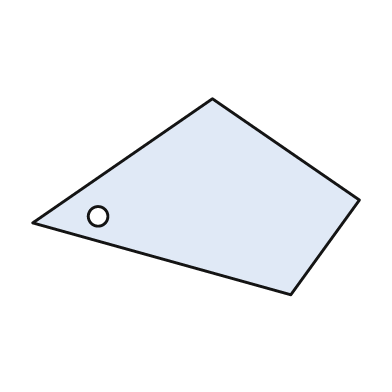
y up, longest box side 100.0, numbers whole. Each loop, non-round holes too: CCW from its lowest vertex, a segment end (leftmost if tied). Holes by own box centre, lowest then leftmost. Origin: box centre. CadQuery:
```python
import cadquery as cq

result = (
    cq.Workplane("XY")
    .moveTo(29.0, -30.0)
    .lineTo(50.0, -1.0)
    .lineTo(5.0, 30.0)
    .lineTo(-50.0, -8.0)
    .close()
    .moveTo(-30.0, -6.0)
    .circle(3.0)
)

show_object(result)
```